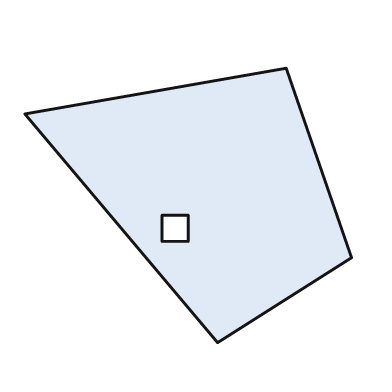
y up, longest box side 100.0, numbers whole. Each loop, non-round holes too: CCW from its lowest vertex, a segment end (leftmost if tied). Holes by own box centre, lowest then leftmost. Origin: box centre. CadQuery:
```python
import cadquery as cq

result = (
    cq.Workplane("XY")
    .moveTo(9.0, -42.0)
    .lineTo(50.0, -16.0)
    .lineTo(30.0, 42.0)
    .lineTo(-50.0, 28.0)
    .close()
    .moveTo(-8.0, -11.0)
    .lineTo(0.0, -11.0)
    .lineTo(0.0, -3.0)
    .lineTo(-8.0, -3.0)
    .close()
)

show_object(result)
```